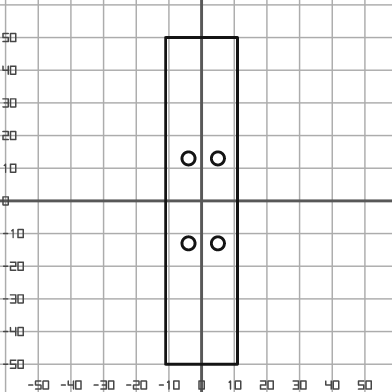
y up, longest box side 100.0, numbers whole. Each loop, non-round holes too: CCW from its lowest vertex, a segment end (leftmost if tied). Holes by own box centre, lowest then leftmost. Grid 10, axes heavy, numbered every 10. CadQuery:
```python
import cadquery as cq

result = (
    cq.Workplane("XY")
    .moveTo(-11.0, -50.0)
    .lineTo(11.0, -50.0)
    .lineTo(11.0, 50.0)
    .lineTo(-11.0, 50.0)
    .close()
    .moveTo(-4.0, -13.0)
    .circle(2.0)
    .moveTo(5.0, -13.0)
    .circle(2.0)
    .moveTo(-4.0, 13.0)
    .circle(2.0)
    .moveTo(5.0, 13.0)
    .circle(2.0)
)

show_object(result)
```